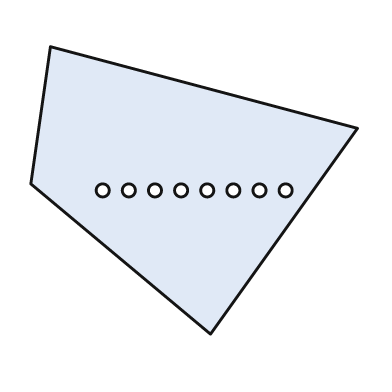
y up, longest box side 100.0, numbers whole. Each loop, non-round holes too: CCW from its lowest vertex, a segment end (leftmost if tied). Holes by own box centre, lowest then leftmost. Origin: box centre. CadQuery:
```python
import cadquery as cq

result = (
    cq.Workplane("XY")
    .moveTo(5.0, -44.0)
    .lineTo(50.0, 19.0)
    .lineTo(-44.0, 44.0)
    .lineTo(-50.0, 2.0)
    .close()
    .moveTo(-28.0, 0.0)
    .circle(2.0)
    .moveTo(-20.0, 0.0)
    .circle(2.0)
    .moveTo(-12.0, 0.0)
    .circle(2.0)
    .moveTo(-4.0, 0.0)
    .circle(2.0)
    .moveTo(4.0, 0.0)
    .circle(2.0)
    .moveTo(12.0, 0.0)
    .circle(2.0)
    .moveTo(20.0, 0.0)
    .circle(2.0)
    .moveTo(28.0, 0.0)
    .circle(2.0)
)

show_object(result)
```